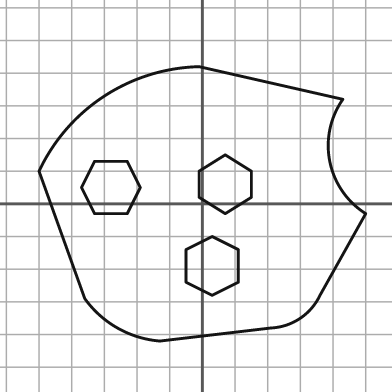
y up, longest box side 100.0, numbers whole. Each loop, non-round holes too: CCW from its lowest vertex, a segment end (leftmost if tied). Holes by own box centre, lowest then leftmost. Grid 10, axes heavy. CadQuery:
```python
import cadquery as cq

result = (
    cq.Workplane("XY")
    .moveTo(-13.0, -42.0)
    .lineTo(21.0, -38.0)
    .threePointArc((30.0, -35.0), (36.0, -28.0))
    .lineTo(50.0, -3.0)
    .threePointArc((39.0, 13.0), (43.0, 32.0))
    .lineTo(-1.0, 42.0)
    .threePointArc((-30.0, 33.0), (-50.0, 10.0))
    .lineTo(-36.0, -29.0)
    .threePointArc((-26.0, -38.0), (-13.0, -42.0))
    .close()
    .moveTo(3.0, -28.0)
    .lineTo(11.0, -24.0)
    .lineTo(11.0, -14.0)
    .lineTo(3.0, -10.0)
    .lineTo(-5.0, -14.0)
    .lineTo(-5.0, -24.0)
    .close()
    .moveTo(-33.0, -3.0)
    .lineTo(-23.0, -3.0)
    .lineTo(-19.0, 5.0)
    .lineTo(-23.0, 13.0)
    .lineTo(-33.0, 13.0)
    .lineTo(-37.0, 5.0)
    .close()
    .moveTo(7.0, -3.0)
    .lineTo(15.0, 2.0)
    .lineTo(15.0, 10.0)
    .lineTo(7.0, 15.0)
    .lineTo(-1.0, 10.0)
    .lineTo(-1.0, 2.0)
    .close()
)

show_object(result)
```